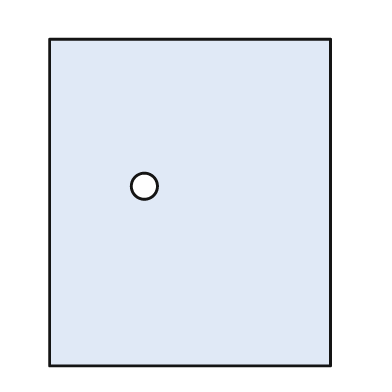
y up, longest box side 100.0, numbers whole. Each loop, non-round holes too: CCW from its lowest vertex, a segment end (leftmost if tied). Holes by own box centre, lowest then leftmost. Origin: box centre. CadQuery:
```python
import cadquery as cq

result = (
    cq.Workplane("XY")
    .moveTo(-43.0, -50.0)
    .lineTo(43.0, -50.0)
    .lineTo(43.0, 50.0)
    .lineTo(-43.0, 50.0)
    .close()
    .moveTo(-14.0, 5.0)
    .circle(4.0)
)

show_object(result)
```